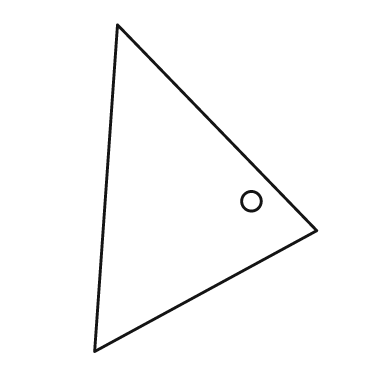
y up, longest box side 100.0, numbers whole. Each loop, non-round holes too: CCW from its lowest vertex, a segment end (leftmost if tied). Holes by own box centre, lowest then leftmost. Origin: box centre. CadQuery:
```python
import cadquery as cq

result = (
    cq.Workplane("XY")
    .moveTo(-34.0, -50.0)
    .lineTo(34.0, -13.0)
    .lineTo(-27.0, 50.0)
    .close()
    .moveTo(14.0, -4.0)
    .circle(3.0)
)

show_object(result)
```